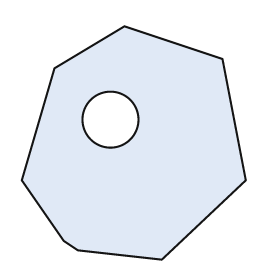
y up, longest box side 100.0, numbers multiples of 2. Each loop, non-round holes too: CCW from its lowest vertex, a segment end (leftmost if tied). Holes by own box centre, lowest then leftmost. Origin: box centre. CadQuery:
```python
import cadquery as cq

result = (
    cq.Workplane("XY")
    .moveTo(12.0, -50.0)
    .lineTo(48.0, -16.0)
    .lineTo(38.0, 36.0)
    .lineTo(-4.0, 50.0)
    .lineTo(-34.0, 32.0)
    .lineTo(-48.0, -16.0)
    .lineTo(-30.0, -42.0)
    .lineTo(-24.0, -46.0)
    .close()
    .moveTo(-10.0, 10.0)
    .circle(12.0)
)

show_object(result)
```